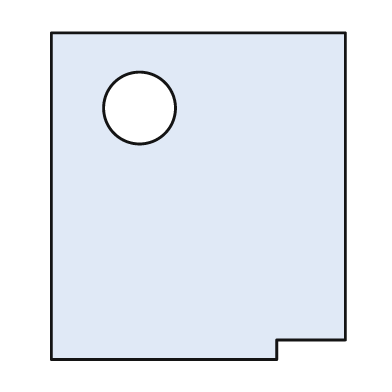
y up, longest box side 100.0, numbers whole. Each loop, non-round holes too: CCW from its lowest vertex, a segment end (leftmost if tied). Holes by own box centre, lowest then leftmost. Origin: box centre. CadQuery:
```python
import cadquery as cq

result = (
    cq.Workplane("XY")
    .moveTo(-45.0, -50.0)
    .lineTo(24.0, -50.0)
    .lineTo(24.0, -44.0)
    .lineTo(45.0, -44.0)
    .lineTo(45.0, 50.0)
    .lineTo(-45.0, 50.0)
    .close()
    .moveTo(-18.0, 27.0)
    .circle(11.0)
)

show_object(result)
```